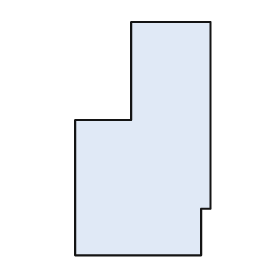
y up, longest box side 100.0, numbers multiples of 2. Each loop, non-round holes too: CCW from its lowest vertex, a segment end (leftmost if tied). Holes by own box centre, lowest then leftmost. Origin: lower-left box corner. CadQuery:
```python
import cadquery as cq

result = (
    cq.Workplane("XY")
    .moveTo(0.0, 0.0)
    .lineTo(54.0, 0.0)
    .lineTo(54.0, 20.0)
    .lineTo(58.0, 20.0)
    .lineTo(58.0, 100.0)
    .lineTo(24.0, 100.0)
    .lineTo(24.0, 58.0)
    .lineTo(0.0, 58.0)
    .close()
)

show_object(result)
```